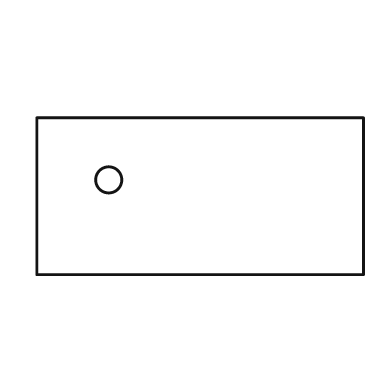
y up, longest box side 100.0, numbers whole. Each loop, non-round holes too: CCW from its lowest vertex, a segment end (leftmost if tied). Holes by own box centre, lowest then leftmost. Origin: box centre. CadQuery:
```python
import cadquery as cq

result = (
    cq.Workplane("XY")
    .moveTo(-50.0, -24.0)
    .lineTo(50.0, -24.0)
    .lineTo(50.0, 24.0)
    .lineTo(-50.0, 24.0)
    .close()
    .moveTo(-28.0, 5.0)
    .circle(4.0)
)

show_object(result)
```